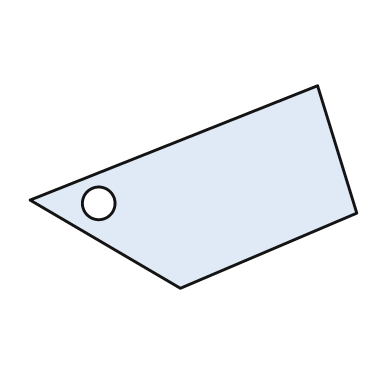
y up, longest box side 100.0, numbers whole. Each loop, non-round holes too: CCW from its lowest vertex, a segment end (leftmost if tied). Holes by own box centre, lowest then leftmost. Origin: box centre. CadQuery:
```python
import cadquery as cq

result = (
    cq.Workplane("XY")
    .moveTo(-4.0, -31.0)
    .lineTo(50.0, -8.0)
    .lineTo(38.0, 31.0)
    .lineTo(-50.0, -4.0)
    .close()
    .moveTo(-29.0, -5.0)
    .circle(5.0)
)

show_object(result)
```